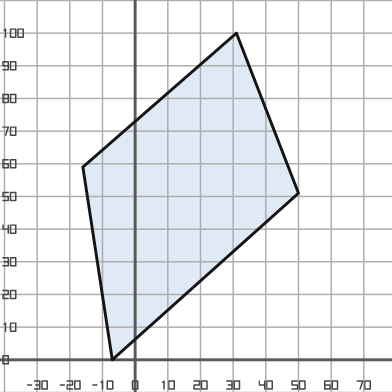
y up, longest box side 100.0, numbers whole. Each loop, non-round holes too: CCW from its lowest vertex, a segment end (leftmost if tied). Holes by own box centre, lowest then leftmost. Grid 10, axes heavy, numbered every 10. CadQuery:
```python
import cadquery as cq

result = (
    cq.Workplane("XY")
    .moveTo(-7.0, 0.0)
    .lineTo(50.0, 51.0)
    .lineTo(31.0, 100.0)
    .lineTo(-16.0, 59.0)
    .close()
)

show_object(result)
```